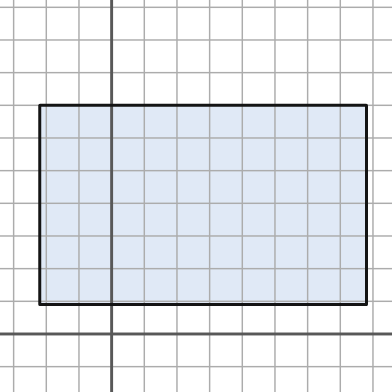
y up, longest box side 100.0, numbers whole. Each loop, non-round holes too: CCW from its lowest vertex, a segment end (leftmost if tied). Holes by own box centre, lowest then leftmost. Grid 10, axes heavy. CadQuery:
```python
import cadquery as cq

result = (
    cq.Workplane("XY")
    .moveTo(-22.0, 9.0)
    .lineTo(78.0, 9.0)
    .lineTo(78.0, 70.0)
    .lineTo(-22.0, 70.0)
    .close()
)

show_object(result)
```